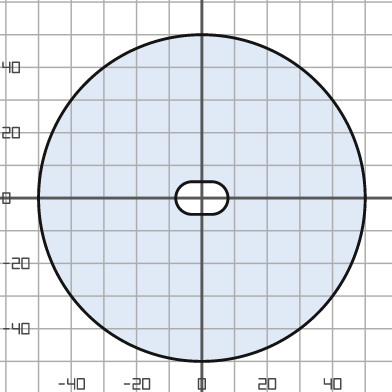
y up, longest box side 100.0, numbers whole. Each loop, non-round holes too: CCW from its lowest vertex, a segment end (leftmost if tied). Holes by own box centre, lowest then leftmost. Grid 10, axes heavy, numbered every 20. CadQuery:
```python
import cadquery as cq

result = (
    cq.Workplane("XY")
    .moveTo(0.0, 0.0)
    .circle(50.0)
    .moveTo(-3.0, -5.0)
    .lineTo(3.0, -5.0)
    .threePointArc((8.0, 0.0), (3.0, 5.0))
    .lineTo(-3.0, 5.0)
    .threePointArc((-8.0, 0.0), (-3.0, -5.0))
    .close()
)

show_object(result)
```